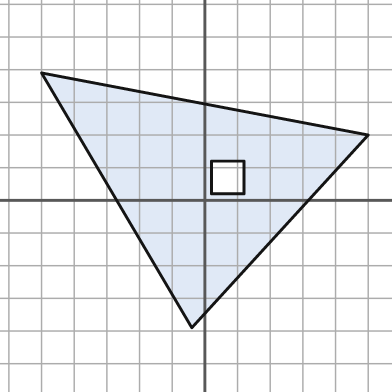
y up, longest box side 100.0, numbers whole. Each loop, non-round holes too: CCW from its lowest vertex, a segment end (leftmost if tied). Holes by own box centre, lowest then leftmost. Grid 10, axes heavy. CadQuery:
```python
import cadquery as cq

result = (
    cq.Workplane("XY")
    .moveTo(-4.0, -39.0)
    .lineTo(50.0, 20.0)
    .lineTo(-50.0, 39.0)
    .close()
    .moveTo(2.0, 2.0)
    .lineTo(12.0, 2.0)
    .lineTo(12.0, 12.0)
    .lineTo(2.0, 12.0)
    .close()
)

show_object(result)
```